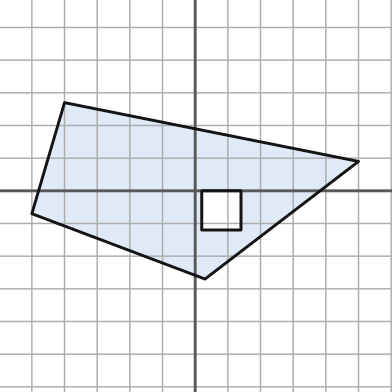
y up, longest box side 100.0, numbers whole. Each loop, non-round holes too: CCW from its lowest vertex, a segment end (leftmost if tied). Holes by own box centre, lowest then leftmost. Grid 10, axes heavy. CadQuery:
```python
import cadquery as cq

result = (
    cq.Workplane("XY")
    .moveTo(3.0, -27.0)
    .lineTo(50.0, 9.0)
    .lineTo(-40.0, 27.0)
    .lineTo(-50.0, -7.0)
    .close()
    .moveTo(2.0, -12.0)
    .lineTo(14.0, -12.0)
    .lineTo(14.0, 0.0)
    .lineTo(2.0, 0.0)
    .close()
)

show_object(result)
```